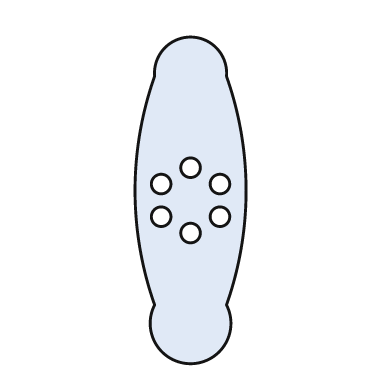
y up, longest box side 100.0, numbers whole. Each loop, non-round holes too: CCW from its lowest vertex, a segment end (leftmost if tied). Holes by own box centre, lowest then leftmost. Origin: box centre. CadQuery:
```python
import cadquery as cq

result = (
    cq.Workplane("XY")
    .moveTo(-11.0, -32.0)
    .threePointArc((0.0, -50.0), (11.0, -32.0))
    .threePointArc((17.0, 3.0), (11.0, 38.0))
    .threePointArc((0.0, 50.0), (-11.0, 38.0))
    .threePointArc((-17.0, 3.0), (-11.0, -32.0))
    .close()
    .moveTo(0.0, -10.0)
    .circle(3.0)
    .moveTo(-9.0, -5.0)
    .circle(3.0)
    .moveTo(9.0, -5.0)
    .circle(3.0)
    .moveTo(-9.0, 5.0)
    .circle(3.0)
    .moveTo(9.0, 5.0)
    .circle(3.0)
    .moveTo(0.0, 10.0)
    .circle(3.0)
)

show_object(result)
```